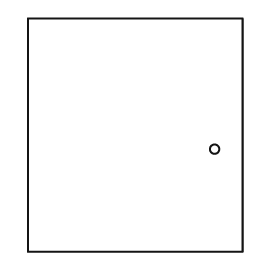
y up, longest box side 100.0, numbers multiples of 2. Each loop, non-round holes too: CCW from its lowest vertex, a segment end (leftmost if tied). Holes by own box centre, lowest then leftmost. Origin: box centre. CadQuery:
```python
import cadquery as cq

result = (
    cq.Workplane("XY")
    .moveTo(-46.0, -50.0)
    .lineTo(46.0, -50.0)
    .lineTo(46.0, 50.0)
    .lineTo(-46.0, 50.0)
    .close()
    .moveTo(34.0, -6.0)
    .circle(2.0)
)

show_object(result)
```